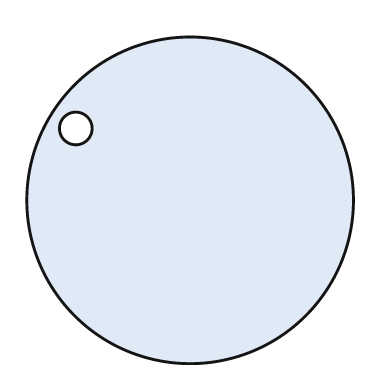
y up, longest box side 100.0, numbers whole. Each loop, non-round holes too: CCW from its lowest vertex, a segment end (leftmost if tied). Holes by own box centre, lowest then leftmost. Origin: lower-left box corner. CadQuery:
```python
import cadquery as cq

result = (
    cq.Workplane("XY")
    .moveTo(50.0, 50.0)
    .circle(50.0)
    .moveTo(15.0, 72.0)
    .circle(5.0)
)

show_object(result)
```